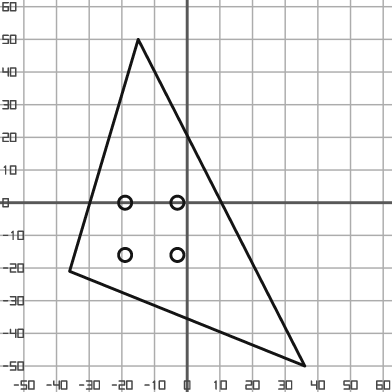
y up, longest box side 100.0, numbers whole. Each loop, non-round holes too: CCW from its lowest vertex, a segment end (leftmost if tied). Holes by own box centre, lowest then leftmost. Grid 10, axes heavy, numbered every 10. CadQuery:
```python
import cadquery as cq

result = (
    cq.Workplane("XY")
    .moveTo(36.0, -50.0)
    .lineTo(-15.0, 50.0)
    .lineTo(-36.0, -21.0)
    .close()
    .moveTo(-19.0, -16.0)
    .circle(2.0)
    .moveTo(-3.0, -16.0)
    .circle(2.0)
    .moveTo(-19.0, 0.0)
    .circle(2.0)
    .moveTo(-3.0, 0.0)
    .circle(2.0)
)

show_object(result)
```